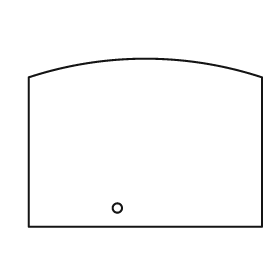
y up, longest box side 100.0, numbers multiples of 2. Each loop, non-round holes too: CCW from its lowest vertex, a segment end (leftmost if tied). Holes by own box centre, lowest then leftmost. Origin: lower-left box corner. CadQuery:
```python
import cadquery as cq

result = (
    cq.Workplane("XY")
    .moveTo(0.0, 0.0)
    .lineTo(100.0, 0.0)
    .lineTo(100.0, 64.0)
    .threePointArc((50.0, 72.0), (0.0, 64.0))
    .close()
    .moveTo(38.0, 8.0)
    .circle(2.0)
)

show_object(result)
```